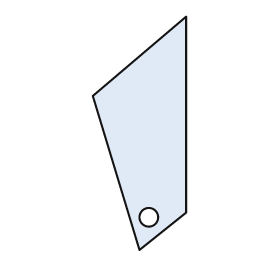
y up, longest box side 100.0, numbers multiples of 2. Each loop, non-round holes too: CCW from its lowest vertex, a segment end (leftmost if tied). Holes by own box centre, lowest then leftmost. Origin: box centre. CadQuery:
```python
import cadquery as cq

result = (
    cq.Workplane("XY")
    .moveTo(0.0, -50.0)
    .lineTo(20.0, -34.0)
    .lineTo(20.0, 50.0)
    .lineTo(-20.0, 16.0)
    .close()
    .moveTo(4.0, -36.0)
    .circle(4.0)
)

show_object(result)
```